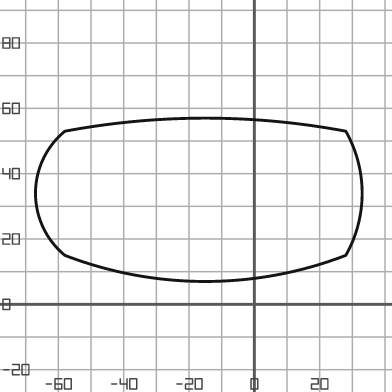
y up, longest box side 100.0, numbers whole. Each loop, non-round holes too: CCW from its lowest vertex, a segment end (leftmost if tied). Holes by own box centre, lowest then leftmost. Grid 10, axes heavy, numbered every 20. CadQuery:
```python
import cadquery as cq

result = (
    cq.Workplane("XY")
    .moveTo(-58.0, 15.0)
    .threePointArc((-15.0, 7.0), (28.0, 15.0))
    .threePointArc((33.0, 34.0), (28.0, 53.0))
    .threePointArc((-15.0, 57.0), (-58.0, 53.0))
    .threePointArc((-67.0, 34.0), (-58.0, 15.0))
    .close()
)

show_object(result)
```